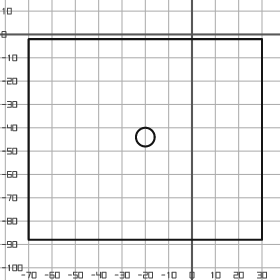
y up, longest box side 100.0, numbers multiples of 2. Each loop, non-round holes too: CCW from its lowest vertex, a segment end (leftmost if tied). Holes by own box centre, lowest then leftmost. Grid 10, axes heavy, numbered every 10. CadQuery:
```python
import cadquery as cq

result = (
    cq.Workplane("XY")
    .moveTo(-70.0, -88.0)
    .lineTo(30.0, -88.0)
    .lineTo(30.0, -2.0)
    .lineTo(-70.0, -2.0)
    .close()
    .moveTo(-20.0, -44.0)
    .circle(4.0)
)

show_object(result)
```